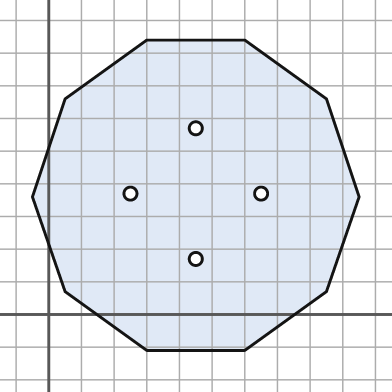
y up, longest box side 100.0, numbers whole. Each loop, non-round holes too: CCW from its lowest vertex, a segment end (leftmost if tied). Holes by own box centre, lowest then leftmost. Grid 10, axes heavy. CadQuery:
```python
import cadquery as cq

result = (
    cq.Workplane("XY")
    .moveTo(30.0, -11.0)
    .lineTo(60.0, -11.0)
    .lineTo(85.0, 7.0)
    .lineTo(95.0, 36.0)
    .lineTo(85.0, 66.0)
    .lineTo(60.0, 84.0)
    .lineTo(30.0, 84.0)
    .lineTo(5.0, 66.0)
    .lineTo(-5.0, 36.0)
    .lineTo(5.0, 7.0)
    .close()
    .moveTo(45.0, 17.0)
    .circle(2.0)
    .moveTo(25.0, 37.0)
    .circle(2.0)
    .moveTo(65.0, 37.0)
    .circle(2.0)
    .moveTo(45.0, 57.0)
    .circle(2.0)
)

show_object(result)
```